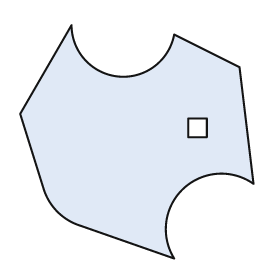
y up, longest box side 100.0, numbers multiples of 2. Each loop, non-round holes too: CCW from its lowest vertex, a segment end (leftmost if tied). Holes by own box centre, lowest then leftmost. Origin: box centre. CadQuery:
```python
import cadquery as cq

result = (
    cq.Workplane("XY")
    .moveTo(16.0, -50.0)
    .threePointArc((20.0, -20.0), (50.0, -18.0))
    .lineTo(44.0, 32.0)
    .lineTo(16.0, 46.0)
    .threePointArc((-8.0, 28.0), (-28.0, 50.0))
    .lineTo(-50.0, 12.0)
    .lineTo(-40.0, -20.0)
    .threePointArc((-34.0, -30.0), (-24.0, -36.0))
    .close()
    .moveTo(22.0, 2.0)
    .lineTo(30.0, 2.0)
    .lineTo(30.0, 10.0)
    .lineTo(22.0, 10.0)
    .close()
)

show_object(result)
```